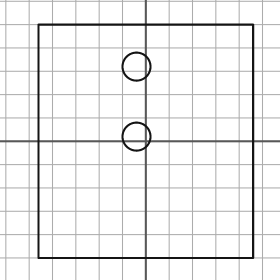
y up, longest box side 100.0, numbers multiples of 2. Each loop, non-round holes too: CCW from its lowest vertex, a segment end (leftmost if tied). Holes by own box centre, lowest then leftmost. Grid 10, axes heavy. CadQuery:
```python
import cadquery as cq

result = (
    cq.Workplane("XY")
    .moveTo(-46.0, -50.0)
    .lineTo(46.0, -50.0)
    .lineTo(46.0, 50.0)
    .lineTo(-46.0, 50.0)
    .close()
    .moveTo(-4.0, 2.0)
    .circle(6.0)
    .moveTo(-4.0, 32.0)
    .circle(6.0)
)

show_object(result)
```